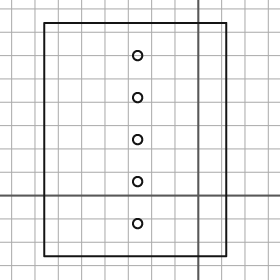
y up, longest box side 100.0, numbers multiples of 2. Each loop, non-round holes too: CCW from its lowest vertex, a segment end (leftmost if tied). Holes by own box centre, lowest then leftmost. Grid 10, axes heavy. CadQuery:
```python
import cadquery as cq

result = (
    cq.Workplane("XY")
    .moveTo(-66.0, -26.0)
    .lineTo(12.0, -26.0)
    .lineTo(12.0, 74.0)
    .lineTo(-66.0, 74.0)
    .close()
    .moveTo(-26.0, -12.0)
    .circle(2.0)
    .moveTo(-26.0, 6.0)
    .circle(2.0)
    .moveTo(-26.0, 24.0)
    .circle(2.0)
    .moveTo(-26.0, 42.0)
    .circle(2.0)
    .moveTo(-26.0, 60.0)
    .circle(2.0)
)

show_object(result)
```